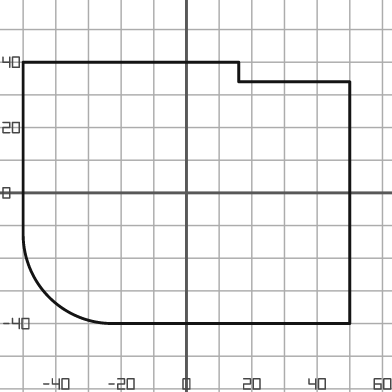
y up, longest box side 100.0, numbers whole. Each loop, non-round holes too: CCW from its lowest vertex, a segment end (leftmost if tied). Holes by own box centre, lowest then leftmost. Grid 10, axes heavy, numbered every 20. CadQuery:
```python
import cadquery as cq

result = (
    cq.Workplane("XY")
    .moveTo(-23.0, -40.0)
    .lineTo(50.0, -40.0)
    .lineTo(50.0, 34.0)
    .lineTo(16.0, 34.0)
    .lineTo(16.0, 40.0)
    .lineTo(-50.0, 40.0)
    .lineTo(-50.0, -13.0)
    .threePointArc((-42.0, -32.0), (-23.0, -40.0))
    .close()
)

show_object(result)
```